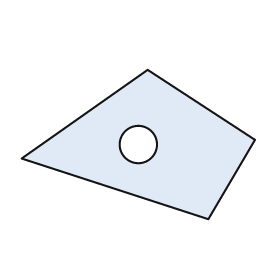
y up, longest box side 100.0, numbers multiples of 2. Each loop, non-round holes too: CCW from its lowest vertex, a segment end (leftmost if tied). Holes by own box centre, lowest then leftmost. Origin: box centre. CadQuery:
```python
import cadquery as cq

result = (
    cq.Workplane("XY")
    .moveTo(30.0, -32.0)
    .lineTo(50.0, 2.0)
    .lineTo(4.0, 32.0)
    .lineTo(-50.0, -6.0)
    .close()
    .moveTo(0.0, 0.0)
    .circle(8.0)
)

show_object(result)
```